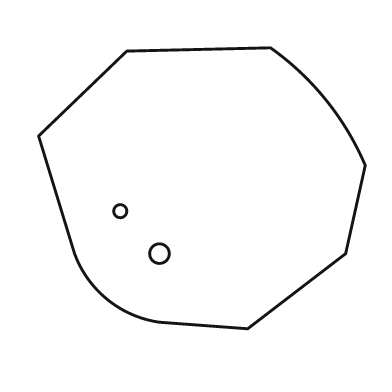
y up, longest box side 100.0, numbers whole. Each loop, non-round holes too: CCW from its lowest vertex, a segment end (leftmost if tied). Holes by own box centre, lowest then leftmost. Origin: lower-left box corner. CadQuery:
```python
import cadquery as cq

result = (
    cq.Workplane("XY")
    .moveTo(64.0, 0.0)
    .lineTo(94.0, 23.0)
    .lineTo(100.0, 50.0)
    .threePointArc((88.0, 70.0), (71.0, 86.0))
    .lineTo(27.0, 85.0)
    .lineTo(0.0, 59.0)
    .lineTo(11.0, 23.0)
    .threePointArc((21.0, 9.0), (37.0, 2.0))
    .close()
    .moveTo(37.0, 23.0)
    .circle(3.0)
    .moveTo(25.0, 36.0)
    .circle(2.0)
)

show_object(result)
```